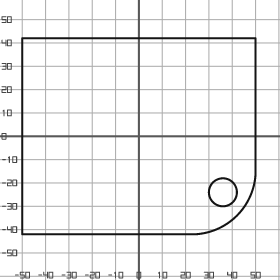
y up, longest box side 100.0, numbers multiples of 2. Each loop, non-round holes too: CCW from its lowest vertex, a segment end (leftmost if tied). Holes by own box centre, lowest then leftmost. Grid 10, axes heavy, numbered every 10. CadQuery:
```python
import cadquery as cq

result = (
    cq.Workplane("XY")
    .moveTo(-50.0, -42.0)
    .lineTo(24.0, -42.0)
    .threePointArc((42.0, -34.0), (50.0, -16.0))
    .lineTo(50.0, 42.0)
    .lineTo(-50.0, 42.0)
    .close()
    .moveTo(36.0, -24.0)
    .circle(6.0)
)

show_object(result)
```